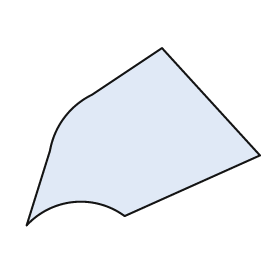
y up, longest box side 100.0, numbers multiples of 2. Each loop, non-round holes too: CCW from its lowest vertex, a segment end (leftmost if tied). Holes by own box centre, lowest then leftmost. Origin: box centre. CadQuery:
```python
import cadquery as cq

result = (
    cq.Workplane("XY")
    .moveTo(-50.0, -38.0)
    .threePointArc((-30.0, -28.0), (-8.0, -34.0))
    .lineTo(50.0, -8.0)
    .lineTo(8.0, 38.0)
    .lineTo(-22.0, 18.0)
    .threePointArc((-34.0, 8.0), (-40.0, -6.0))
    .close()
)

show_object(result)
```